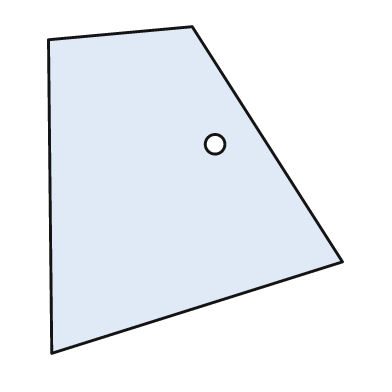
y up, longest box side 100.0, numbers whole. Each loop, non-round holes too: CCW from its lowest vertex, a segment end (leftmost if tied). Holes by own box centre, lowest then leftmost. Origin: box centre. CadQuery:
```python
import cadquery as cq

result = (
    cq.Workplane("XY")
    .moveTo(-44.0, -50.0)
    .lineTo(45.0, -22.0)
    .lineTo(-1.0, 50.0)
    .lineTo(-45.0, 46.0)
    .close()
    .moveTo(6.0, 14.0)
    .circle(3.0)
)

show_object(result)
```